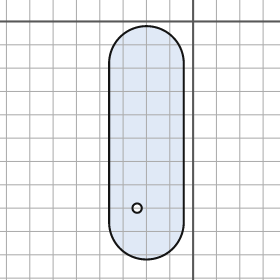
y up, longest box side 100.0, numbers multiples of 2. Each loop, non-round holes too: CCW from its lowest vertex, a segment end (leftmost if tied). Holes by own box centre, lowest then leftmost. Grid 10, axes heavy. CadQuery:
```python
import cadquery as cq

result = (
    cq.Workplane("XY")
    .moveTo(-36.0, -86.0)
    .threePointArc((-20.0, -102.0), (-4.0, -86.0))
    .lineTo(-4.0, -18.0)
    .threePointArc((-20.0, -2.0), (-36.0, -18.0))
    .close()
    .moveTo(-24.0, -80.0)
    .circle(2.0)
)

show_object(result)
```